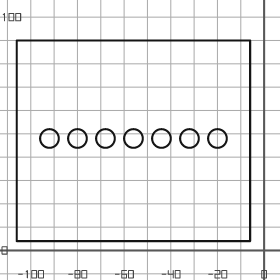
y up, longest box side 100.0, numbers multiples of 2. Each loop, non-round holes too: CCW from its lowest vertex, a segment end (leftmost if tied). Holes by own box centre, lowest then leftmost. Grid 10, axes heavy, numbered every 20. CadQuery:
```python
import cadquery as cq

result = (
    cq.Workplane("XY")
    .moveTo(-106.0, 4.0)
    .lineTo(-6.0, 4.0)
    .lineTo(-6.0, 90.0)
    .lineTo(-106.0, 90.0)
    .close()
    .moveTo(-92.0, 48.0)
    .circle(4.0)
    .moveTo(-80.0, 48.0)
    .circle(4.0)
    .moveTo(-68.0, 48.0)
    .circle(4.0)
    .moveTo(-56.0, 48.0)
    .circle(4.0)
    .moveTo(-44.0, 48.0)
    .circle(4.0)
    .moveTo(-32.0, 48.0)
    .circle(4.0)
    .moveTo(-20.0, 48.0)
    .circle(4.0)
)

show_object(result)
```